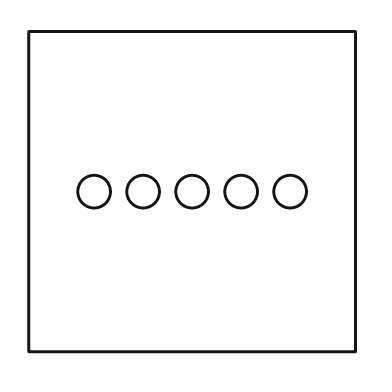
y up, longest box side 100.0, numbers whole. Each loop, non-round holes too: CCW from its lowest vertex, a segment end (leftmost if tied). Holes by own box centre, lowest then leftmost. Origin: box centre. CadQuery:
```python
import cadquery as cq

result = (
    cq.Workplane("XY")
    .moveTo(-50.0, -49.0)
    .lineTo(50.0, -49.0)
    .lineTo(50.0, 49.0)
    .lineTo(-50.0, 49.0)
    .close()
    .moveTo(-30.0, 0.0)
    .circle(5.0)
    .moveTo(-15.0, 0.0)
    .circle(5.0)
    .moveTo(0.0, 0.0)
    .circle(5.0)
    .moveTo(15.0, 0.0)
    .circle(5.0)
    .moveTo(30.0, 0.0)
    .circle(5.0)
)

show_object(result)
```